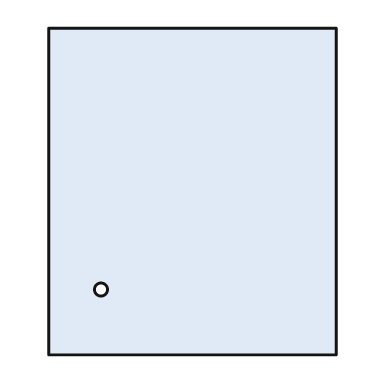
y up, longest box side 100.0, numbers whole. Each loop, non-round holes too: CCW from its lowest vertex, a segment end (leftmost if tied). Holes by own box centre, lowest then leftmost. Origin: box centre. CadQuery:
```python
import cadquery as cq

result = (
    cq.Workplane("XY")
    .moveTo(-44.0, -50.0)
    .lineTo(44.0, -50.0)
    .lineTo(44.0, 50.0)
    .lineTo(-44.0, 50.0)
    .close()
    .moveTo(-28.0, -30.0)
    .circle(2.0)
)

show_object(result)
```